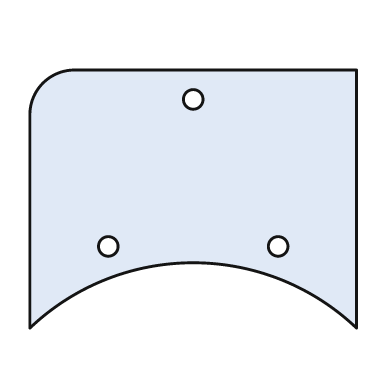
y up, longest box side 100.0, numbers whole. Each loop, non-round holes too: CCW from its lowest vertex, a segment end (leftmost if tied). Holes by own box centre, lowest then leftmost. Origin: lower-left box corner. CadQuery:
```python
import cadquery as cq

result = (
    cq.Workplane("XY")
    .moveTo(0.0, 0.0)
    .threePointArc((50.0, 20.0), (100.0, 0.0))
    .lineTo(100.0, 79.0)
    .lineTo(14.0, 79.0)
    .threePointArc((4.0, 75.0), (0.0, 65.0))
    .close()
    .moveTo(24.0, 25.0)
    .circle(3.0)
    .moveTo(76.0, 25.0)
    .circle(3.0)
    .moveTo(50.0, 70.0)
    .circle(3.0)
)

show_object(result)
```